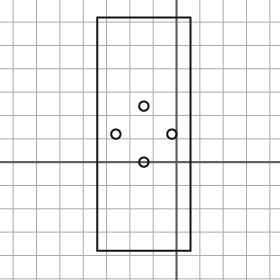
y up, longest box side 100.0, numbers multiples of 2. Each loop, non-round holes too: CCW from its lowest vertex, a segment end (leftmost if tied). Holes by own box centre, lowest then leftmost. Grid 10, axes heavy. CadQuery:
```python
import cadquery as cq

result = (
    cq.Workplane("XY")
    .moveTo(-34.0, -38.0)
    .lineTo(6.0, -38.0)
    .lineTo(6.0, 62.0)
    .lineTo(-34.0, 62.0)
    .close()
    .moveTo(-14.0, 0.0)
    .circle(2.0)
    .moveTo(-26.0, 12.0)
    .circle(2.0)
    .moveTo(-2.0, 12.0)
    .circle(2.0)
    .moveTo(-14.0, 24.0)
    .circle(2.0)
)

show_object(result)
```